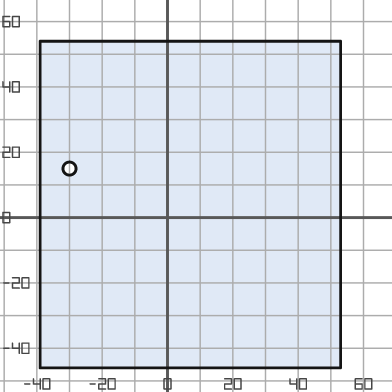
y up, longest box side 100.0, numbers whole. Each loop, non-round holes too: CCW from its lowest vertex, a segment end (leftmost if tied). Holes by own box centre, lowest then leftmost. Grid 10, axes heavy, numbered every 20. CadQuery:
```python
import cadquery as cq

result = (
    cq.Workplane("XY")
    .moveTo(-39.0, -46.0)
    .lineTo(53.0, -46.0)
    .lineTo(53.0, 54.0)
    .lineTo(-39.0, 54.0)
    .close()
    .moveTo(-30.0, 15.0)
    .circle(2.0)
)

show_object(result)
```